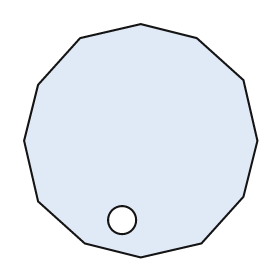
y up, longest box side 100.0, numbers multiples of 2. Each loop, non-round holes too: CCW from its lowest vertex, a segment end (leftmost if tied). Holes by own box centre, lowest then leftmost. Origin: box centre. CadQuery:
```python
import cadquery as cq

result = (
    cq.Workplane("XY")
    .moveTo(0.0, -50.0)
    .lineTo(26.0, -44.0)
    .lineTo(44.0, -24.0)
    .lineTo(50.0, 0.0)
    .lineTo(44.0, 26.0)
    .lineTo(24.0, 44.0)
    .lineTo(0.0, 50.0)
    .lineTo(-26.0, 44.0)
    .lineTo(-44.0, 24.0)
    .lineTo(-50.0, 0.0)
    .lineTo(-44.0, -26.0)
    .lineTo(-24.0, -44.0)
    .close()
    .moveTo(-8.0, -34.0)
    .circle(6.0)
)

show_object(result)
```